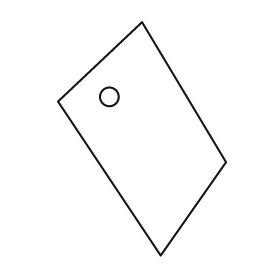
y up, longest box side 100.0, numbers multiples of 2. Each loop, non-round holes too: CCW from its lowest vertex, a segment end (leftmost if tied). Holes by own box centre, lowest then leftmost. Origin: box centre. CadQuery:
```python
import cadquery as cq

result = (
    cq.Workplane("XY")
    .moveTo(8.0, -50.0)
    .lineTo(36.0, -10.0)
    .lineTo(0.0, 50.0)
    .lineTo(-36.0, 16.0)
    .close()
    .moveTo(-14.0, 18.0)
    .circle(4.0)
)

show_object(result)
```